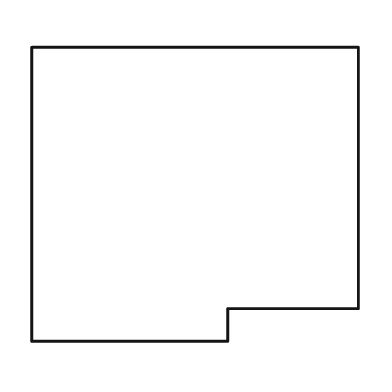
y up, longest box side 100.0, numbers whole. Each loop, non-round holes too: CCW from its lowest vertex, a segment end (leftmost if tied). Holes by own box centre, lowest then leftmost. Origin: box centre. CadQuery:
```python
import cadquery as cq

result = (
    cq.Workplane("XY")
    .moveTo(-50.0, -45.0)
    .lineTo(10.0, -45.0)
    .lineTo(10.0, -35.0)
    .lineTo(50.0, -35.0)
    .lineTo(50.0, 45.0)
    .lineTo(-50.0, 45.0)
    .close()
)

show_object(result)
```